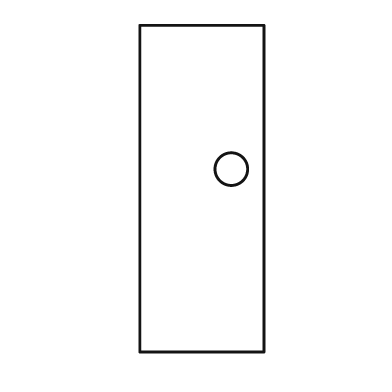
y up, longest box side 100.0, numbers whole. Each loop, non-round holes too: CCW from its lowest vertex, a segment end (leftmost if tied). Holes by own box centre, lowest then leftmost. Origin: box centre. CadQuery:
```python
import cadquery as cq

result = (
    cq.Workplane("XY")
    .moveTo(-19.0, -50.0)
    .lineTo(19.0, -50.0)
    .lineTo(19.0, 50.0)
    .lineTo(-19.0, 50.0)
    .close()
    .moveTo(9.0, 6.0)
    .circle(5.0)
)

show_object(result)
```